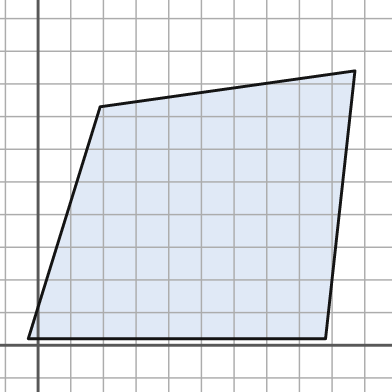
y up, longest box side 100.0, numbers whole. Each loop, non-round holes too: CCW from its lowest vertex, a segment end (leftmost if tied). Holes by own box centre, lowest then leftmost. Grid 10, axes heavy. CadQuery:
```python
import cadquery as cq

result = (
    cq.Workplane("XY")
    .moveTo(-3.0, 2.0)
    .lineTo(88.0, 2.0)
    .lineTo(97.0, 84.0)
    .lineTo(19.0, 73.0)
    .close()
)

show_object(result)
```